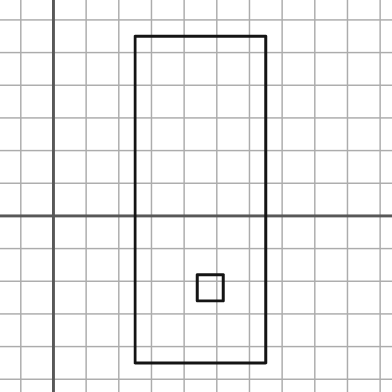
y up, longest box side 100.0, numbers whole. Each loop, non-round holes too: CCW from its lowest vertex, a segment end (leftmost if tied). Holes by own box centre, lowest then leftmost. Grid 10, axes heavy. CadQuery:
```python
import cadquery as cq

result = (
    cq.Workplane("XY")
    .moveTo(25.0, -45.0)
    .lineTo(65.0, -45.0)
    .lineTo(65.0, 55.0)
    .lineTo(25.0, 55.0)
    .close()
    .moveTo(44.0, -26.0)
    .lineTo(52.0, -26.0)
    .lineTo(52.0, -18.0)
    .lineTo(44.0, -18.0)
    .close()
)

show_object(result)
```